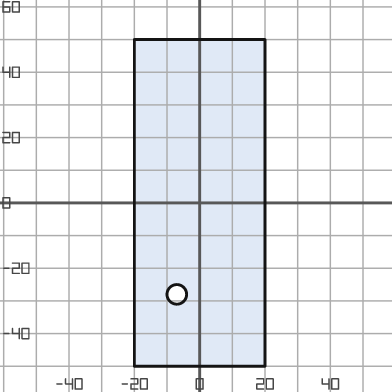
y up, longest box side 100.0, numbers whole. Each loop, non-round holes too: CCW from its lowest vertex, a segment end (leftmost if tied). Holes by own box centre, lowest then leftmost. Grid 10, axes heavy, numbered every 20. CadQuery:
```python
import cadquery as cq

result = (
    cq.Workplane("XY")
    .moveTo(-20.0, -50.0)
    .lineTo(20.0, -50.0)
    .lineTo(20.0, 50.0)
    .lineTo(-20.0, 50.0)
    .close()
    .moveTo(-7.0, -28.0)
    .circle(3.0)
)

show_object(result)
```